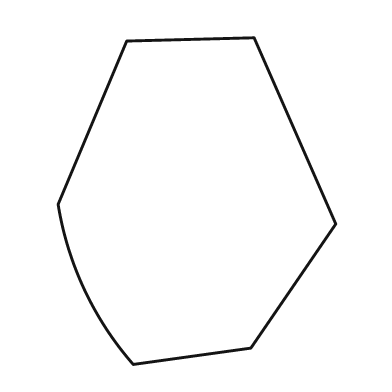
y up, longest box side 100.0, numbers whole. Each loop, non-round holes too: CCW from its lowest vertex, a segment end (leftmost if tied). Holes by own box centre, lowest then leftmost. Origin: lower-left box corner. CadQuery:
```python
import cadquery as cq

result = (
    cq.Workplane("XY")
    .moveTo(23.0, 0.0)
    .lineTo(59.0, 5.0)
    .lineTo(85.0, 43.0)
    .lineTo(60.0, 100.0)
    .lineTo(21.0, 99.0)
    .lineTo(0.0, 49.0)
    .threePointArc((8.0, 23.0), (23.0, 0.0))
    .close()
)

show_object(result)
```